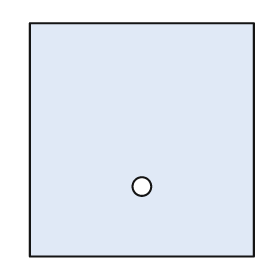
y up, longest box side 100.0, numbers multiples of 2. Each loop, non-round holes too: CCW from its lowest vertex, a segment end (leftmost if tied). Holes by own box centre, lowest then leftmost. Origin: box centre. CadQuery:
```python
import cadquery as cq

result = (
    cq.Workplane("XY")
    .moveTo(-48.0, -50.0)
    .lineTo(48.0, -50.0)
    .lineTo(48.0, 50.0)
    .lineTo(-48.0, 50.0)
    .close()
    .moveTo(0.0, -20.0)
    .circle(4.0)
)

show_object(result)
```